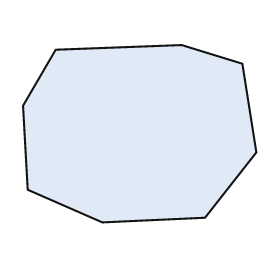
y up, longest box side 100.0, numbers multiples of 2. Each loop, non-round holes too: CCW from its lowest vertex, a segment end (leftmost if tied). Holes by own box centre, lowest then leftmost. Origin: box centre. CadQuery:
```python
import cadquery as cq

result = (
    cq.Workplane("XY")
    .moveTo(-16.0, -38.0)
    .lineTo(28.0, -36.0)
    .lineTo(50.0, -8.0)
    .lineTo(44.0, 30.0)
    .lineTo(18.0, 38.0)
    .lineTo(-36.0, 36.0)
    .lineTo(-50.0, 12.0)
    .lineTo(-48.0, -24.0)
    .close()
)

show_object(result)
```